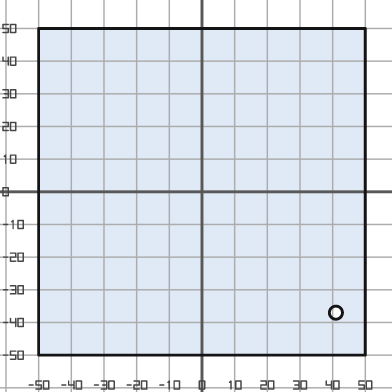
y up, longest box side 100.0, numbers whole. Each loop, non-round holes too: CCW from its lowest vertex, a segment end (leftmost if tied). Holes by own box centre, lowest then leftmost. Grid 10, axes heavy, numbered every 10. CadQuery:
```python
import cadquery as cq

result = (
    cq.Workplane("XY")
    .moveTo(-50.0, -50.0)
    .lineTo(50.0, -50.0)
    .lineTo(50.0, 50.0)
    .lineTo(-50.0, 50.0)
    .close()
    .moveTo(41.0, -37.0)
    .circle(2.0)
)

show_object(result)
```